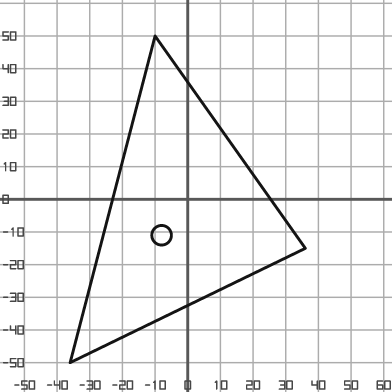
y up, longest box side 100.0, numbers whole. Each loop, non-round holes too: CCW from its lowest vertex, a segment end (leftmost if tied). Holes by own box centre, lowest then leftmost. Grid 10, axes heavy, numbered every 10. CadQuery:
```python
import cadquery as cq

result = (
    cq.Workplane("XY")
    .moveTo(-36.0, -50.0)
    .lineTo(36.0, -15.0)
    .lineTo(-10.0, 50.0)
    .close()
    .moveTo(-8.0, -11.0)
    .circle(3.0)
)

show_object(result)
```